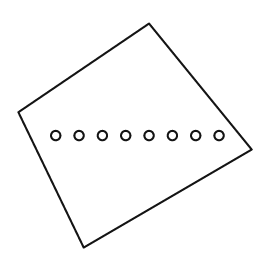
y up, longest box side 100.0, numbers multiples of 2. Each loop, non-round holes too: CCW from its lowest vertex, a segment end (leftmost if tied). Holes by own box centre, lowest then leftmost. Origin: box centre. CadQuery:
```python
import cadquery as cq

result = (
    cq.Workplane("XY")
    .moveTo(-22.0, -48.0)
    .lineTo(50.0, -6.0)
    .lineTo(6.0, 48.0)
    .lineTo(-50.0, 10.0)
    .close()
    .moveTo(-34.0, 0.0)
    .circle(2.0)
    .moveTo(-24.0, 0.0)
    .circle(2.0)
    .moveTo(-14.0, 0.0)
    .circle(2.0)
    .moveTo(-4.0, 0.0)
    .circle(2.0)
    .moveTo(6.0, 0.0)
    .circle(2.0)
    .moveTo(16.0, 0.0)
    .circle(2.0)
    .moveTo(26.0, 0.0)
    .circle(2.0)
    .moveTo(36.0, 0.0)
    .circle(2.0)
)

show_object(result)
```